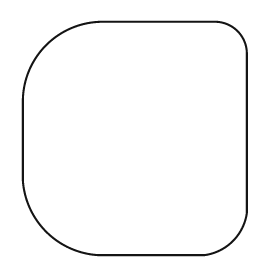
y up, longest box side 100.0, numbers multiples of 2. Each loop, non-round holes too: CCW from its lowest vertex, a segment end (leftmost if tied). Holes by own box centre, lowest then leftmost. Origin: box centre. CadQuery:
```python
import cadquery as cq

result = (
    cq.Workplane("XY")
    .moveTo(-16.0, -50.0)
    .lineTo(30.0, -50.0)
    .threePointArc((42.0, -44.0), (48.0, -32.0))
    .lineTo(48.0, 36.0)
    .threePointArc((44.0, 46.0), (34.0, 50.0))
    .lineTo(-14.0, 50.0)
    .threePointArc((-38.0, 40.0), (-48.0, 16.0))
    .lineTo(-48.0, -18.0)
    .threePointArc((-38.0, -40.0), (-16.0, -50.0))
    .close()
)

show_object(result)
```